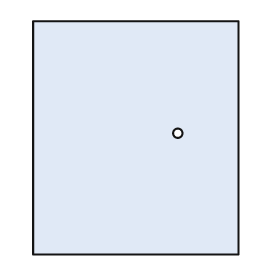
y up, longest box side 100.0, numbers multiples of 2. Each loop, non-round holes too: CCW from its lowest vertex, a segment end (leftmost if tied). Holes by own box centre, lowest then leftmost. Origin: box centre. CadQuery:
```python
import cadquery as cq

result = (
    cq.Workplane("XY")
    .moveTo(-44.0, -50.0)
    .lineTo(44.0, -50.0)
    .lineTo(44.0, 50.0)
    .lineTo(-44.0, 50.0)
    .close()
    .moveTo(18.0, 2.0)
    .circle(2.0)
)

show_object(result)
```